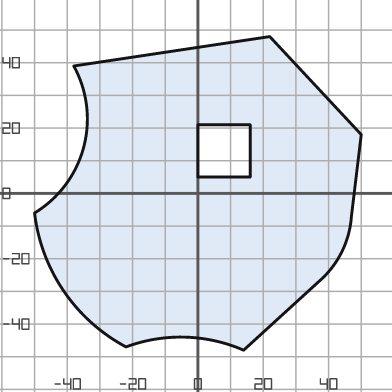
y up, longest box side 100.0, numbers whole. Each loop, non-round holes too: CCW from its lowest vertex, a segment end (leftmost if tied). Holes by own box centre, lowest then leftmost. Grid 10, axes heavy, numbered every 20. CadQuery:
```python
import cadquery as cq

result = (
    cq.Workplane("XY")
    .moveTo(14.0, -48.0)
    .lineTo(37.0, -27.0)
    .threePointArc((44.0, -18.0), (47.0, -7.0))
    .lineTo(50.0, 18.0)
    .lineTo(22.0, 48.0)
    .lineTo(-38.0, 39.0)
    .threePointArc((-35.0, 14.0), (-50.0, -6.0))
    .threePointArc((-41.0, -30.0), (-22.0, -47.0))
    .threePointArc((-4.0, -44.0), (14.0, -48.0))
    .close()
    .moveTo(0.0, 5.0)
    .lineTo(16.0, 5.0)
    .lineTo(16.0, 21.0)
    .lineTo(0.0, 21.0)
    .close()
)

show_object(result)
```